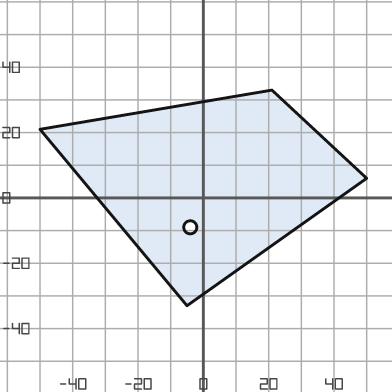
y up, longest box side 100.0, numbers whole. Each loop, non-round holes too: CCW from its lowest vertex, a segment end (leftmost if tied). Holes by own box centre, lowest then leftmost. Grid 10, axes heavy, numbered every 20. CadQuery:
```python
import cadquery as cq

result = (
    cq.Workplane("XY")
    .moveTo(-5.0, -33.0)
    .lineTo(50.0, 6.0)
    .lineTo(21.0, 33.0)
    .lineTo(-50.0, 21.0)
    .close()
    .moveTo(-4.0, -9.0)
    .circle(2.0)
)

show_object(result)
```